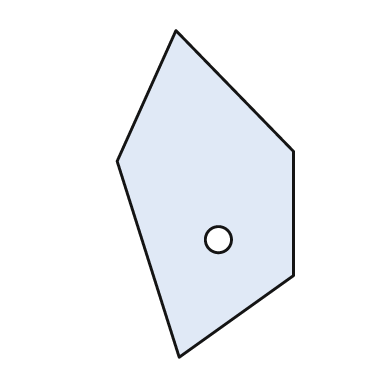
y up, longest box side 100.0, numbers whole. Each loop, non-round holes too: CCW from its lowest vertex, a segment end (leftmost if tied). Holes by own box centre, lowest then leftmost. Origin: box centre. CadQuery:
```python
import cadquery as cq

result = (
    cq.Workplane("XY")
    .moveTo(-8.0, -50.0)
    .lineTo(27.0, -25.0)
    .lineTo(27.0, 13.0)
    .lineTo(-9.0, 50.0)
    .lineTo(-27.0, 10.0)
    .close()
    .moveTo(4.0, -14.0)
    .circle(4.0)
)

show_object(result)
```